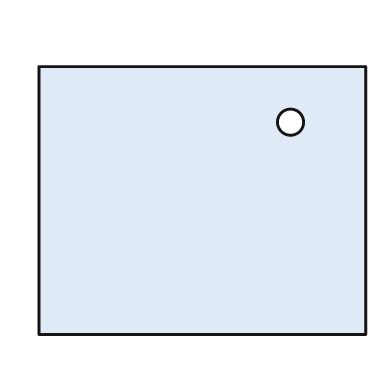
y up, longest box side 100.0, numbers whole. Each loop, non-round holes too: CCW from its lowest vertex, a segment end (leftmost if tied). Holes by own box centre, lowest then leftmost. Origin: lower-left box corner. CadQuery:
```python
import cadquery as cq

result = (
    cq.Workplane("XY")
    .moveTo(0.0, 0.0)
    .lineTo(100.0, 0.0)
    .lineTo(100.0, 82.0)
    .lineTo(0.0, 82.0)
    .close()
    .moveTo(77.0, 65.0)
    .circle(4.0)
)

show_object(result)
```